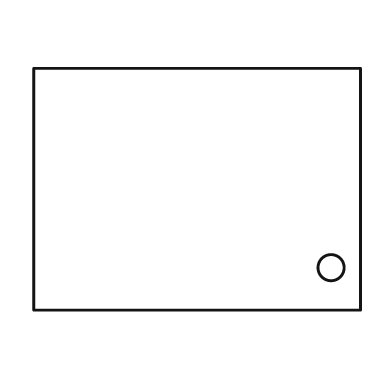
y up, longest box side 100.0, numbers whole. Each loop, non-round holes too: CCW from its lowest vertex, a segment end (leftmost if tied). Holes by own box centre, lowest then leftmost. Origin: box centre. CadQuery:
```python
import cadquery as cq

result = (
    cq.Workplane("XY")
    .moveTo(-50.0, -37.0)
    .lineTo(50.0, -37.0)
    .lineTo(50.0, 37.0)
    .lineTo(-50.0, 37.0)
    .close()
    .moveTo(41.0, -24.0)
    .circle(4.0)
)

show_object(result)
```